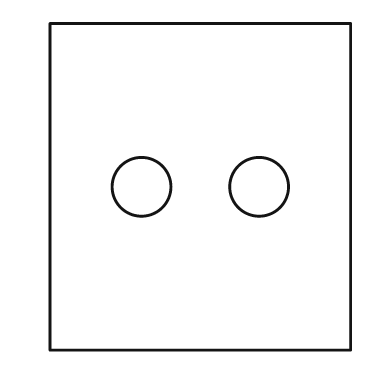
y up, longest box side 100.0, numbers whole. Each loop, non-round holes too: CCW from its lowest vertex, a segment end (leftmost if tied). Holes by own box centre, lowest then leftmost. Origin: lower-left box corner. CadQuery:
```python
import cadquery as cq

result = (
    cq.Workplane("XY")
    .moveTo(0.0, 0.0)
    .lineTo(92.0, 0.0)
    .lineTo(92.0, 100.0)
    .lineTo(0.0, 100.0)
    .close()
    .moveTo(28.0, 50.0)
    .circle(9.0)
    .moveTo(64.0, 50.0)
    .circle(9.0)
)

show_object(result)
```